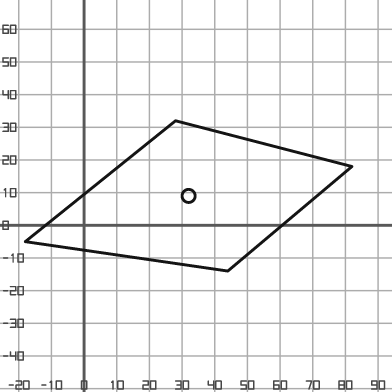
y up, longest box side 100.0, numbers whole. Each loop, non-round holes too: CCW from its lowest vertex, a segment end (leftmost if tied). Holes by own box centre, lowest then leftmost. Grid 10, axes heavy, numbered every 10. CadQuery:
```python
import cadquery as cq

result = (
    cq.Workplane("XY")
    .moveTo(44.0, -14.0)
    .lineTo(82.0, 18.0)
    .lineTo(28.0, 32.0)
    .lineTo(-18.0, -5.0)
    .close()
    .moveTo(32.0, 9.0)
    .circle(2.0)
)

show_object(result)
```